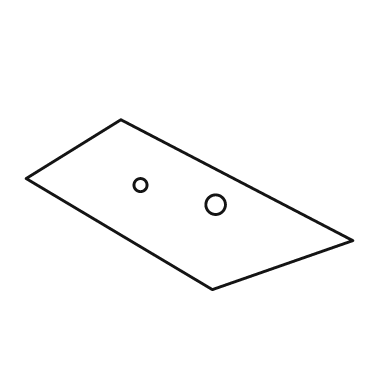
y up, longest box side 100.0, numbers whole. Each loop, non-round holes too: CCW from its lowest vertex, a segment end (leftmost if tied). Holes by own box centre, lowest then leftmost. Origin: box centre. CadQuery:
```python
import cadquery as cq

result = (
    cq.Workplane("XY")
    .moveTo(7.0, -26.0)
    .lineTo(50.0, -11.0)
    .lineTo(-21.0, 26.0)
    .lineTo(-50.0, 8.0)
    .close()
    .moveTo(8.0, 0.0)
    .circle(3.0)
    .moveTo(-15.0, 6.0)
    .circle(2.0)
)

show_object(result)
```